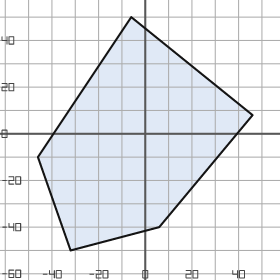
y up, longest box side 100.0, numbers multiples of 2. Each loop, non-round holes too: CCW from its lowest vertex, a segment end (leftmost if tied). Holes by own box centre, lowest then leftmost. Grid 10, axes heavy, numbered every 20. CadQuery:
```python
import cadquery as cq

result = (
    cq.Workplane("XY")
    .moveTo(-32.0, -50.0)
    .lineTo(6.0, -40.0)
    .lineTo(46.0, 8.0)
    .lineTo(-6.0, 50.0)
    .lineTo(-46.0, -10.0)
    .close()
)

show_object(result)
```